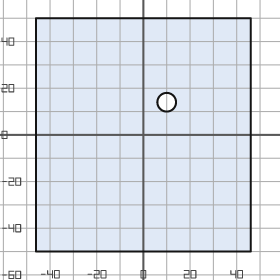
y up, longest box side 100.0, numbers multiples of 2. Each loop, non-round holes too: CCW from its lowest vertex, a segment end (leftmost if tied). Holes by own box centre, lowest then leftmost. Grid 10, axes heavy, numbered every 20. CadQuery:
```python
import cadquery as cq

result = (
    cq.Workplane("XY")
    .moveTo(-46.0, -50.0)
    .lineTo(46.0, -50.0)
    .lineTo(46.0, 50.0)
    .lineTo(-46.0, 50.0)
    .close()
    .moveTo(10.0, 14.0)
    .circle(4.0)
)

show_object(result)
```